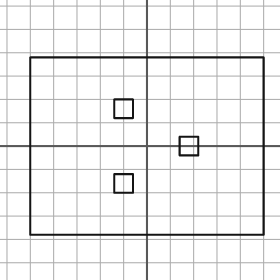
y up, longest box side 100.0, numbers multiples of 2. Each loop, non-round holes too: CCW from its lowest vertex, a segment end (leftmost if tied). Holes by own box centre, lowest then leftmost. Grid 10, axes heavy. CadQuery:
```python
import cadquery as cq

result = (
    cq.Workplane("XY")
    .moveTo(-50.0, -38.0)
    .lineTo(50.0, -38.0)
    .lineTo(50.0, 38.0)
    .lineTo(-50.0, 38.0)
    .close()
    .moveTo(-14.0, -20.0)
    .lineTo(-6.0, -20.0)
    .lineTo(-6.0, -12.0)
    .lineTo(-14.0, -12.0)
    .close()
    .moveTo(14.0, -4.0)
    .lineTo(22.0, -4.0)
    .lineTo(22.0, 4.0)
    .lineTo(14.0, 4.0)
    .close()
    .moveTo(-14.0, 12.0)
    .lineTo(-6.0, 12.0)
    .lineTo(-6.0, 20.0)
    .lineTo(-14.0, 20.0)
    .close()
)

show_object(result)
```